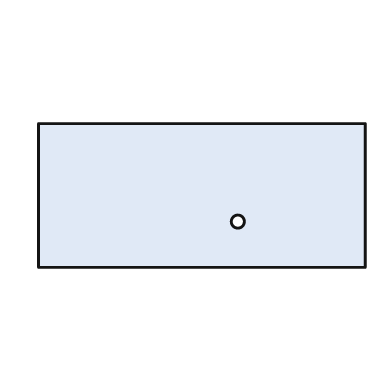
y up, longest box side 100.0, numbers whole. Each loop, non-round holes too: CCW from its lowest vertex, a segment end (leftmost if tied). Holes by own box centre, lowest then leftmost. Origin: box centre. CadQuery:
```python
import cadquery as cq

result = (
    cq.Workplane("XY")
    .moveTo(-50.0, -22.0)
    .lineTo(50.0, -22.0)
    .lineTo(50.0, 22.0)
    .lineTo(-50.0, 22.0)
    .close()
    .moveTo(11.0, -8.0)
    .circle(2.0)
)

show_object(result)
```